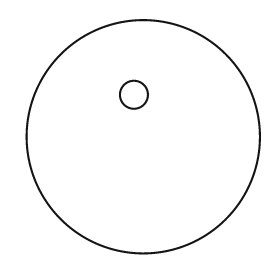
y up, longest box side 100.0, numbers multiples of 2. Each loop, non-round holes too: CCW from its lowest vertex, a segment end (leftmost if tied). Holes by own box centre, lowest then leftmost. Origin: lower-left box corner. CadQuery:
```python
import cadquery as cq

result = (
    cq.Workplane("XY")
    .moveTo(50.0, 50.0)
    .circle(50.0)
    .moveTo(46.0, 68.0)
    .circle(6.0)
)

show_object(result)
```